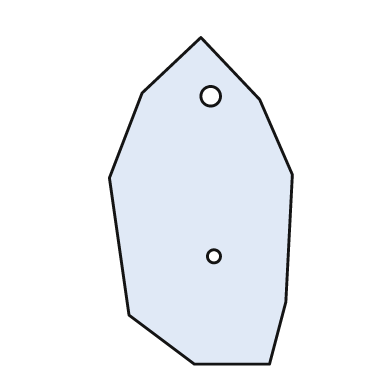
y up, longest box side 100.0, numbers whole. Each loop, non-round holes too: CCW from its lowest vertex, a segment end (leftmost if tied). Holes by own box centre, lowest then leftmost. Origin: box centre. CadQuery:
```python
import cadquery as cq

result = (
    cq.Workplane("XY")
    .moveTo(-2.0, -50.0)
    .lineTo(21.0, -50.0)
    .lineTo(26.0, -31.0)
    .lineTo(28.0, 8.0)
    .lineTo(18.0, 31.0)
    .lineTo(0.0, 50.0)
    .lineTo(-18.0, 33.0)
    .lineTo(-28.0, 7.0)
    .lineTo(-22.0, -35.0)
    .close()
    .moveTo(4.0, -17.0)
    .circle(2.0)
    .moveTo(3.0, 32.0)
    .circle(3.0)
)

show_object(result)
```